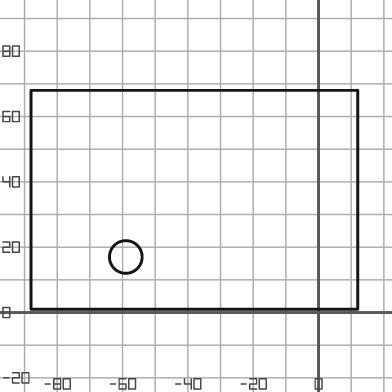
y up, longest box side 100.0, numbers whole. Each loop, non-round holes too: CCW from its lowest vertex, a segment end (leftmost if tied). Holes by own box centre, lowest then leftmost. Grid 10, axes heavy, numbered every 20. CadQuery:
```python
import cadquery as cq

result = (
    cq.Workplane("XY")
    .moveTo(-88.0, 1.0)
    .lineTo(12.0, 1.0)
    .lineTo(12.0, 68.0)
    .lineTo(-88.0, 68.0)
    .close()
    .moveTo(-59.0, 17.0)
    .circle(5.0)
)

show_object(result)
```